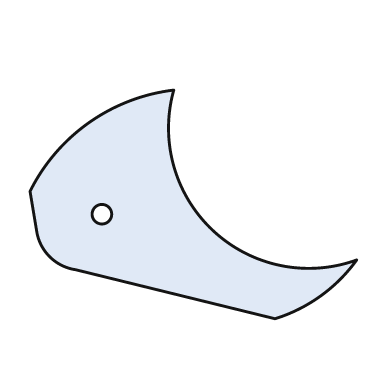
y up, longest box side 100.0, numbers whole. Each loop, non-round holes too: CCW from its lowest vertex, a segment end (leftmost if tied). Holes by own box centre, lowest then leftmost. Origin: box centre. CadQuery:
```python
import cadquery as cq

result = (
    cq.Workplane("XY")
    .moveTo(25.0, -35.0)
    .threePointArc((39.0, -28.0), (50.0, -17.0))
    .threePointArc((6.0, -8.0), (-6.0, 35.0))
    .threePointArc((-32.0, 25.0), (-50.0, 4.0))
    .lineTo(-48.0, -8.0)
    .threePointArc((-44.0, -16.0), (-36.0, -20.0))
    .close()
    .moveTo(-28.0, -3.0)
    .circle(3.0)
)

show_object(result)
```